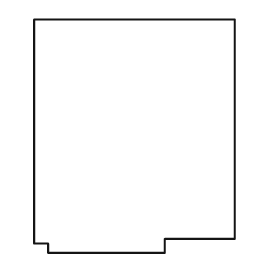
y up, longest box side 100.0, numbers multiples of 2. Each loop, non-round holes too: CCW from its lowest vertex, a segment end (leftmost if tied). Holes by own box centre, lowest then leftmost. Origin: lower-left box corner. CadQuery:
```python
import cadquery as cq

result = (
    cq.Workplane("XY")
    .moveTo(6.0, 0.0)
    .lineTo(56.0, 0.0)
    .lineTo(56.0, 6.0)
    .lineTo(86.0, 6.0)
    .lineTo(86.0, 100.0)
    .lineTo(0.0, 100.0)
    .lineTo(0.0, 4.0)
    .lineTo(6.0, 4.0)
    .close()
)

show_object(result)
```